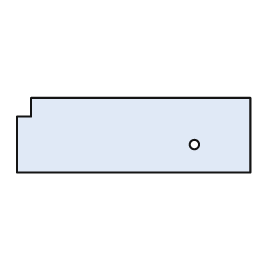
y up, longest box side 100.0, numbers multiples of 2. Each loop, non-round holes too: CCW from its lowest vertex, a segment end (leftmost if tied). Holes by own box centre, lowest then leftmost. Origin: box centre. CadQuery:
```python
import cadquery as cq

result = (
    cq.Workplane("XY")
    .moveTo(-50.0, -16.0)
    .lineTo(50.0, -16.0)
    .lineTo(50.0, 16.0)
    .lineTo(-44.0, 16.0)
    .lineTo(-44.0, 8.0)
    .lineTo(-50.0, 8.0)
    .close()
    .moveTo(26.0, -4.0)
    .circle(2.0)
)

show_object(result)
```